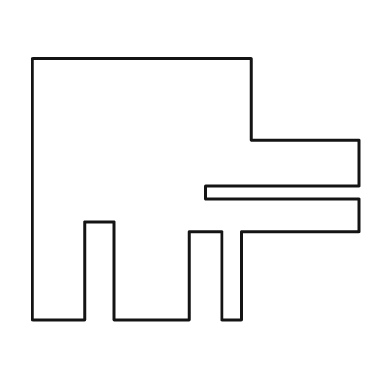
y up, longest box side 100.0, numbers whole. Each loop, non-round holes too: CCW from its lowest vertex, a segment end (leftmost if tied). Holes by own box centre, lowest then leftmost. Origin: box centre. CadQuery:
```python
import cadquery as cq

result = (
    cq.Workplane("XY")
    .moveTo(-50.0, -40.0)
    .lineTo(-34.0, -40.0)
    .lineTo(-34.0, -10.0)
    .lineTo(-25.0, -10.0)
    .lineTo(-25.0, -40.0)
    .lineTo(-2.0, -40.0)
    .lineTo(-2.0, -13.0)
    .lineTo(8.0, -13.0)
    .lineTo(8.0, -40.0)
    .lineTo(14.0, -40.0)
    .lineTo(14.0, -13.0)
    .lineTo(50.0, -13.0)
    .lineTo(50.0, -3.0)
    .lineTo(3.0, -3.0)
    .lineTo(3.0, 1.0)
    .lineTo(50.0, 1.0)
    .lineTo(50.0, 15.0)
    .lineTo(17.0, 15.0)
    .lineTo(17.0, 40.0)
    .lineTo(-50.0, 40.0)
    .close()
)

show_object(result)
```